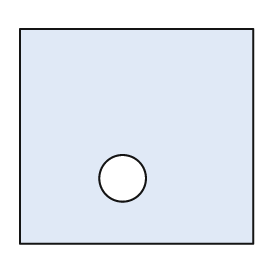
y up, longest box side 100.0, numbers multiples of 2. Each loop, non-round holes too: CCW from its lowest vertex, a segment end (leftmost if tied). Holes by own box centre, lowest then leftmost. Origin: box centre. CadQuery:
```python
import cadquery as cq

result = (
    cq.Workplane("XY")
    .moveTo(-50.0, -46.0)
    .lineTo(50.0, -46.0)
    .lineTo(50.0, 46.0)
    .lineTo(-50.0, 46.0)
    .close()
    .moveTo(-6.0, -18.0)
    .circle(10.0)
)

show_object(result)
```